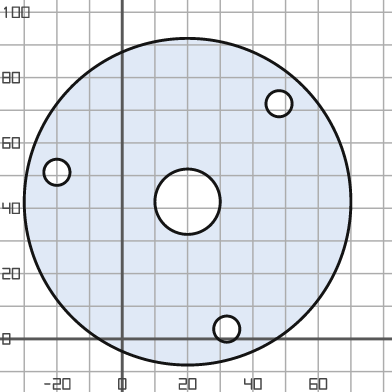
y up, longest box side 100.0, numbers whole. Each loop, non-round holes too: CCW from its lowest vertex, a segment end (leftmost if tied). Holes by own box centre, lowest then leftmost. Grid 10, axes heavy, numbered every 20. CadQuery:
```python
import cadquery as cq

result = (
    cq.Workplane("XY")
    .moveTo(20.0, 42.0)
    .circle(50.0)
    .moveTo(32.0, 3.0)
    .circle(4.0)
    .moveTo(20.0, 42.0)
    .circle(10.0)
    .moveTo(-20.0, 51.0)
    .circle(4.0)
    .moveTo(48.0, 72.0)
    .circle(4.0)
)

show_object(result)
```